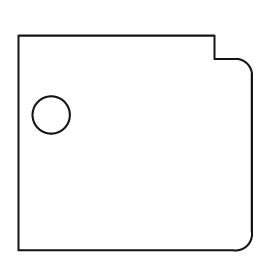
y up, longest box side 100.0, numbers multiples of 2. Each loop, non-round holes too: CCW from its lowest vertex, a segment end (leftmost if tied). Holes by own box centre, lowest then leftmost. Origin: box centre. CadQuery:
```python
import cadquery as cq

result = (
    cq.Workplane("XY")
    .moveTo(-50.0, -46.0)
    .lineTo(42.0, -46.0)
    .threePointArc((48.0, -44.0), (50.0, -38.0))
    .lineTo(50.0, 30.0)
    .threePointArc((48.0, 34.0), (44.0, 36.0))
    .lineTo(34.0, 36.0)
    .lineTo(34.0, 46.0)
    .lineTo(-50.0, 46.0)
    .close()
    .moveTo(-36.0, 12.0)
    .circle(8.0)
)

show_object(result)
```